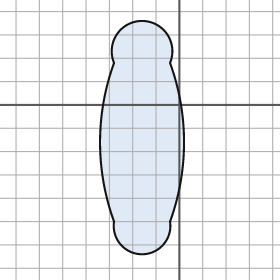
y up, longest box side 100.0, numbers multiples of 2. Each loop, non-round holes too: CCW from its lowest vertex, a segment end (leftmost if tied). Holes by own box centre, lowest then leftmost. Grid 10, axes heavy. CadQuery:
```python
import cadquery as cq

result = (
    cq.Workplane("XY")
    .moveTo(-28.0, -50.0)
    .threePointArc((-16.0, -64.0), (-4.0, -50.0))
    .threePointArc((2.0, -16.0), (-4.0, 18.0))
    .threePointArc((-16.0, 36.0), (-28.0, 18.0))
    .threePointArc((-34.0, -16.0), (-28.0, -50.0))
    .close()
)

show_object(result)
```